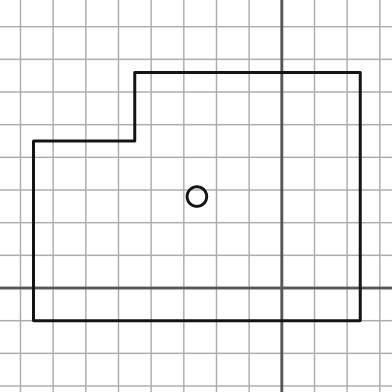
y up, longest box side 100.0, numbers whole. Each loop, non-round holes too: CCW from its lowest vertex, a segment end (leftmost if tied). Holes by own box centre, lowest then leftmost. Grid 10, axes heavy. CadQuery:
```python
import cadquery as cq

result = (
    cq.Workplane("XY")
    .moveTo(-76.0, -10.0)
    .lineTo(24.0, -10.0)
    .lineTo(24.0, 66.0)
    .lineTo(-45.0, 66.0)
    .lineTo(-45.0, 45.0)
    .lineTo(-76.0, 45.0)
    .close()
    .moveTo(-26.0, 28.0)
    .circle(3.0)
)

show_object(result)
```